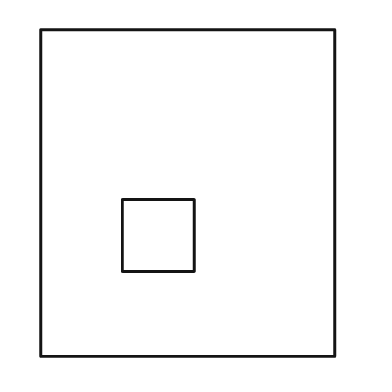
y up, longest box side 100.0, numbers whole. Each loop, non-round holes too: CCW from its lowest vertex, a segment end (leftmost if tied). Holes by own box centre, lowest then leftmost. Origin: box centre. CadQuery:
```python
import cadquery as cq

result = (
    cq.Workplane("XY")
    .moveTo(-45.0, -50.0)
    .lineTo(45.0, -50.0)
    .lineTo(45.0, 50.0)
    .lineTo(-45.0, 50.0)
    .close()
    .moveTo(-20.0, -24.0)
    .lineTo(2.0, -24.0)
    .lineTo(2.0, -2.0)
    .lineTo(-20.0, -2.0)
    .close()
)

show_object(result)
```